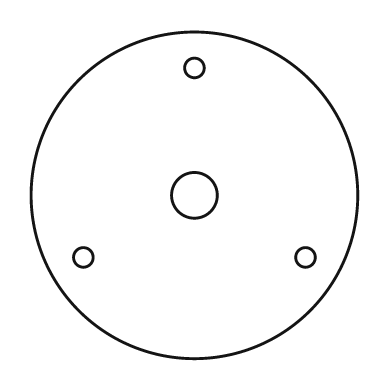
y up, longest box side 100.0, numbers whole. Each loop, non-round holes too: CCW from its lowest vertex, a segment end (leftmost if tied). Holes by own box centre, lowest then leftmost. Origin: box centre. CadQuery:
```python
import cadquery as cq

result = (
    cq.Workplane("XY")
    .moveTo(0.0, 0.0)
    .circle(50.0)
    .moveTo(-34.0, -19.0)
    .circle(3.0)
    .moveTo(34.0, -19.0)
    .circle(3.0)
    .moveTo(0.0, 0.0)
    .circle(7.0)
    .moveTo(0.0, 39.0)
    .circle(3.0)
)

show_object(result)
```